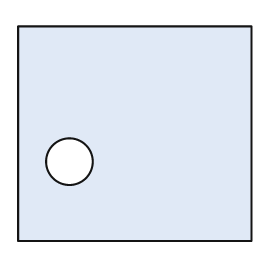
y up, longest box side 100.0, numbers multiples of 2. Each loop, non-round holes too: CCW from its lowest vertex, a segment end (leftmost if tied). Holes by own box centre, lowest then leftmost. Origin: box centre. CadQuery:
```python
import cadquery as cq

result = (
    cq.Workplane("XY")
    .moveTo(-50.0, -46.0)
    .lineTo(50.0, -46.0)
    .lineTo(50.0, 46.0)
    .lineTo(-50.0, 46.0)
    .close()
    .moveTo(-28.0, -12.0)
    .circle(10.0)
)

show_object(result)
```